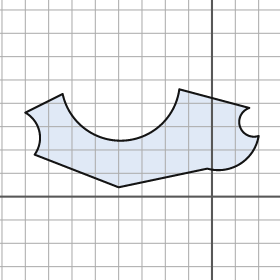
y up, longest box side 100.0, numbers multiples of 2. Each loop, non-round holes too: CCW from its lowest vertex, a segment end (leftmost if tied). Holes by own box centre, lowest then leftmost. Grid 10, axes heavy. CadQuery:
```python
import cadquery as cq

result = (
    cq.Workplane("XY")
    .moveTo(-40.0, 4.0)
    .lineTo(-2.0, 12.0)
    .threePointArc((12.0, 14.0), (20.0, 26.0))
    .threePointArc((12.0, 30.0), (16.0, 38.0))
    .lineTo(-14.0, 46.0)
    .threePointArc((-38.0, 24.0), (-64.0, 44.0))
    .lineTo(-80.0, 36.0)
    .threePointArc((-74.0, 28.0), (-76.0, 18.0))
    .close()
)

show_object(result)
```